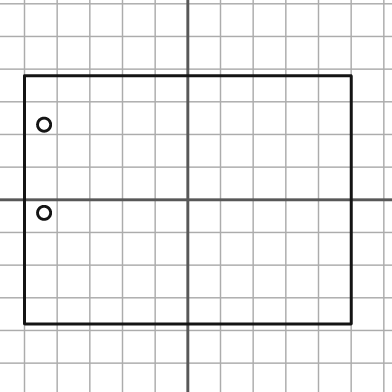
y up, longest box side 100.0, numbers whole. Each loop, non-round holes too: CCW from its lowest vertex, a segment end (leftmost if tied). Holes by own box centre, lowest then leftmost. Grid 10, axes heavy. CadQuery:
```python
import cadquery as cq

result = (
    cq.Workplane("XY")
    .moveTo(-50.0, -38.0)
    .lineTo(50.0, -38.0)
    .lineTo(50.0, 38.0)
    .lineTo(-50.0, 38.0)
    .close()
    .moveTo(-44.0, -4.0)
    .circle(2.0)
    .moveTo(-44.0, 23.0)
    .circle(2.0)
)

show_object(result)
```